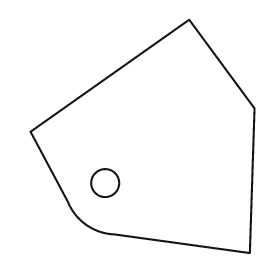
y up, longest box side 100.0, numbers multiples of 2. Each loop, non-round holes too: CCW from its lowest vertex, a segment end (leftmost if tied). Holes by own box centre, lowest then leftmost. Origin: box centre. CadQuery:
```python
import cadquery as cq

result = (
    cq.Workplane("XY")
    .moveTo(46.0, -50.0)
    .lineTo(48.0, 12.0)
    .lineTo(20.0, 50.0)
    .lineTo(-48.0, 2.0)
    .lineTo(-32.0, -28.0)
    .threePointArc((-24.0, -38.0), (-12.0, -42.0))
    .close()
    .moveTo(-16.0, -20.0)
    .circle(6.0)
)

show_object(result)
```